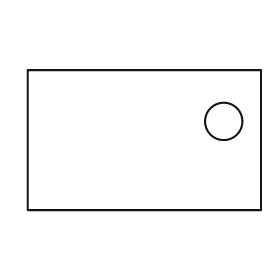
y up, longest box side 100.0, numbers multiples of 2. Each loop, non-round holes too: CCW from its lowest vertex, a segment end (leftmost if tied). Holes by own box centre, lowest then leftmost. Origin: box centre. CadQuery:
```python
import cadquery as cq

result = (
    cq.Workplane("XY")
    .moveTo(-50.0, -30.0)
    .lineTo(50.0, -30.0)
    .lineTo(50.0, 30.0)
    .lineTo(-50.0, 30.0)
    .close()
    .moveTo(34.0, 8.0)
    .circle(8.0)
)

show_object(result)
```